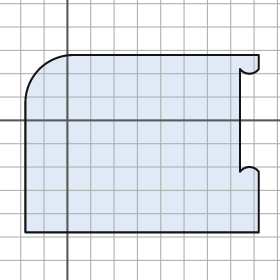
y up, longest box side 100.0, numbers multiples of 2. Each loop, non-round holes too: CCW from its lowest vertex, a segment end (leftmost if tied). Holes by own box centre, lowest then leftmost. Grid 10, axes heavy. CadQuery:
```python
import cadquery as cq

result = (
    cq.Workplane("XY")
    .moveTo(-18.0, -48.0)
    .lineTo(82.0, -48.0)
    .lineTo(82.0, -22.0)
    .threePointArc((78.0, -20.0), (74.0, -22.0))
    .lineTo(74.0, 22.0)
    .threePointArc((78.0, 20.0), (82.0, 22.0))
    .lineTo(82.0, 28.0)
    .lineTo(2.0, 28.0)
    .threePointArc((-12.0, 22.0), (-18.0, 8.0))
    .close()
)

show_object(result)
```